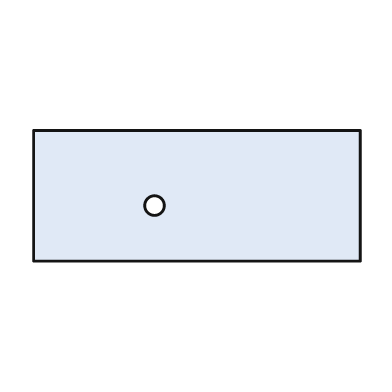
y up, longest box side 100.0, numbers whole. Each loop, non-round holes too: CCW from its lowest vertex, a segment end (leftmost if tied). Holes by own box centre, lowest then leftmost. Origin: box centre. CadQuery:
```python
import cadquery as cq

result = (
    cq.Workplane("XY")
    .moveTo(-50.0, -20.0)
    .lineTo(50.0, -20.0)
    .lineTo(50.0, 20.0)
    .lineTo(-50.0, 20.0)
    .close()
    .moveTo(-13.0, -3.0)
    .circle(3.0)
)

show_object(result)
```